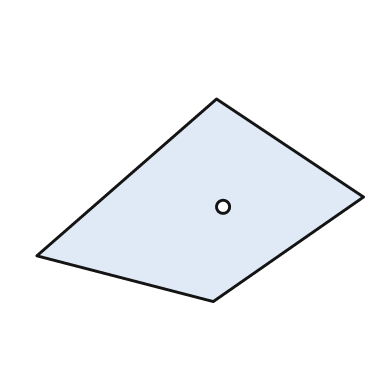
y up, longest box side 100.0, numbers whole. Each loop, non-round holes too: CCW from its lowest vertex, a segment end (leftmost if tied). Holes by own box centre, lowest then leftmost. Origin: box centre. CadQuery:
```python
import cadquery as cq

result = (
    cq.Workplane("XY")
    .moveTo(4.0, -31.0)
    .lineTo(50.0, 1.0)
    .lineTo(5.0, 31.0)
    .lineTo(-50.0, -17.0)
    .close()
    .moveTo(7.0, -2.0)
    .circle(2.0)
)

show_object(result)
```